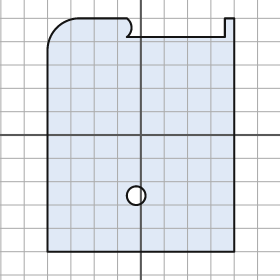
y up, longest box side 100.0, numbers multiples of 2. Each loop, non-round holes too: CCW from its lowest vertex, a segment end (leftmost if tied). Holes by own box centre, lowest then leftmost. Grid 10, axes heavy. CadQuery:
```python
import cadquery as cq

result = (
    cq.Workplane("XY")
    .moveTo(-40.0, -50.0)
    .lineTo(40.0, -50.0)
    .lineTo(40.0, 50.0)
    .lineTo(36.0, 50.0)
    .lineTo(36.0, 42.0)
    .lineTo(-6.0, 42.0)
    .threePointArc((-4.0, 46.0), (-6.0, 50.0))
    .lineTo(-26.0, 50.0)
    .threePointArc((-36.0, 46.0), (-40.0, 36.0))
    .close()
    .moveTo(-2.0, -26.0)
    .circle(4.0)
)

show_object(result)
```